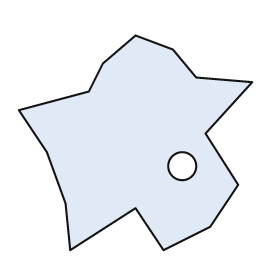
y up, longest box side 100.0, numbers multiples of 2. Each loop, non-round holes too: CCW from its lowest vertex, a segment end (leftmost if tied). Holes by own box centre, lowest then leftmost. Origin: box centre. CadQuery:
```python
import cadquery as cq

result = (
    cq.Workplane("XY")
    .moveTo(-28.0, -46.0)
    .lineTo(0.0, -28.0)
    .lineTo(12.0, -46.0)
    .lineTo(32.0, -36.0)
    .lineTo(44.0, -18.0)
    .lineTo(30.0, 4.0)
    .lineTo(50.0, 26.0)
    .lineTo(26.0, 28.0)
    .lineTo(16.0, 40.0)
    .lineTo(0.0, 46.0)
    .lineTo(-14.0, 34.0)
    .lineTo(-20.0, 22.0)
    .lineTo(-50.0, 14.0)
    .lineTo(-38.0, -4.0)
    .lineTo(-30.0, -26.0)
    .close()
    .moveTo(20.0, -10.0)
    .circle(6.0)
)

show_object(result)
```